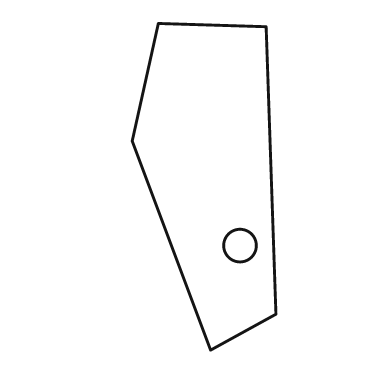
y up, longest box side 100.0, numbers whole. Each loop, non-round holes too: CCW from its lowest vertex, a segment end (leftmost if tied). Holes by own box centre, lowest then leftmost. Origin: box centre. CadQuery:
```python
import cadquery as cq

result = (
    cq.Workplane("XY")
    .moveTo(2.0, -50.0)
    .lineTo(22.0, -39.0)
    .lineTo(19.0, 49.0)
    .lineTo(-14.0, 50.0)
    .lineTo(-22.0, 14.0)
    .close()
    .moveTo(11.0, -18.0)
    .circle(5.0)
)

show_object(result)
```